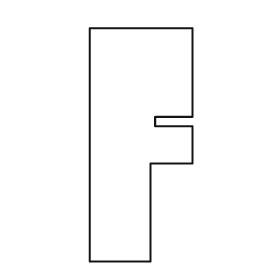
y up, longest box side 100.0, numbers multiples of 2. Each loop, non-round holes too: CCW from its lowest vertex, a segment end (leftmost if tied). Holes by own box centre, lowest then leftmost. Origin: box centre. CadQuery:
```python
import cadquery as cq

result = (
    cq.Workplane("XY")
    .moveTo(-22.0, -50.0)
    .lineTo(4.0, -50.0)
    .lineTo(4.0, -8.0)
    .lineTo(22.0, -8.0)
    .lineTo(22.0, 8.0)
    .lineTo(6.0, 8.0)
    .lineTo(6.0, 12.0)
    .lineTo(22.0, 12.0)
    .lineTo(22.0, 50.0)
    .lineTo(-22.0, 50.0)
    .close()
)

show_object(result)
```